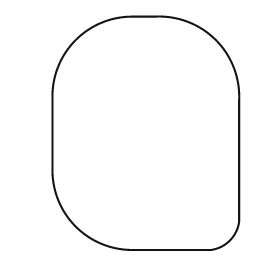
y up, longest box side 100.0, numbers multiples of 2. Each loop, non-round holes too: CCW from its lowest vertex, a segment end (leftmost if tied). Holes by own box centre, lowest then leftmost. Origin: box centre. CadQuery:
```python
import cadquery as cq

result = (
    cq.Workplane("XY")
    .moveTo(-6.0, -50.0)
    .lineTo(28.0, -50.0)
    .threePointArc((36.0, -46.0), (40.0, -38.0))
    .lineTo(40.0, 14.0)
    .threePointArc((30.0, 40.0), (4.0, 50.0))
    .lineTo(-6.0, 50.0)
    .threePointArc((-30.0, 40.0), (-40.0, 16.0))
    .lineTo(-40.0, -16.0)
    .threePointArc((-30.0, -40.0), (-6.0, -50.0))
    .close()
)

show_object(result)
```